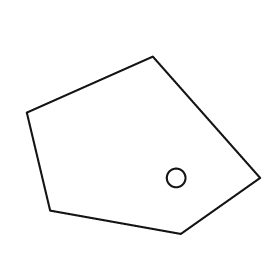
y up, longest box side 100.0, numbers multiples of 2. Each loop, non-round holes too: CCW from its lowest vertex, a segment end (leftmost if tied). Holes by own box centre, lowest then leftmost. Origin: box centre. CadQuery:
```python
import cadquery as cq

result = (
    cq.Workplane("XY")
    .moveTo(16.0, -38.0)
    .lineTo(50.0, -14.0)
    .lineTo(4.0, 38.0)
    .lineTo(-50.0, 14.0)
    .lineTo(-40.0, -28.0)
    .close()
    .moveTo(14.0, -14.0)
    .circle(4.0)
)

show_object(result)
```